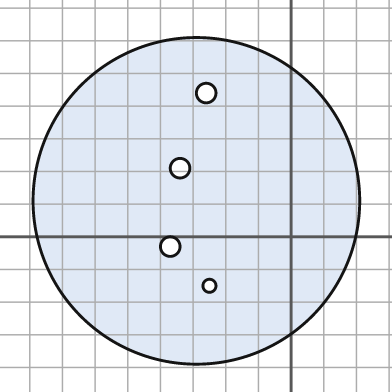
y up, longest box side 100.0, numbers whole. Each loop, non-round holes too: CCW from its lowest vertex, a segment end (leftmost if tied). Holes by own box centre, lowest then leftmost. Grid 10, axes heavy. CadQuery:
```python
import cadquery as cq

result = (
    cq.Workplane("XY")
    .moveTo(-29.0, 11.0)
    .circle(50.0)
    .moveTo(-25.0, -15.0)
    .circle(2.0)
    .moveTo(-37.0, -3.0)
    .circle(3.0)
    .moveTo(-34.0, 21.0)
    .circle(3.0)
    .moveTo(-26.0, 44.0)
    .circle(3.0)
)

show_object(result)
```